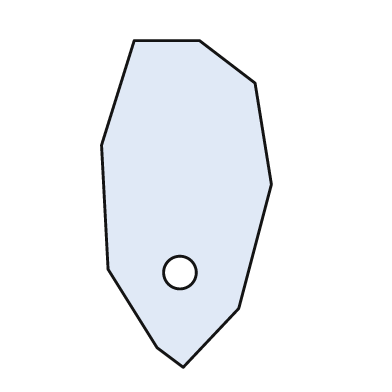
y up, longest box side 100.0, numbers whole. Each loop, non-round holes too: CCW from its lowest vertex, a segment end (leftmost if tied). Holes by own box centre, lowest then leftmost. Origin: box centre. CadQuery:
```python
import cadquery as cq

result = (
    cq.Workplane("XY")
    .moveTo(-1.0, -50.0)
    .lineTo(16.0, -32.0)
    .lineTo(26.0, 6.0)
    .lineTo(21.0, 37.0)
    .lineTo(4.0, 50.0)
    .lineTo(-16.0, 50.0)
    .lineTo(-26.0, 18.0)
    .lineTo(-24.0, -20.0)
    .lineTo(-9.0, -44.0)
    .close()
    .moveTo(-2.0, -21.0)
    .circle(5.0)
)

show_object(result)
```